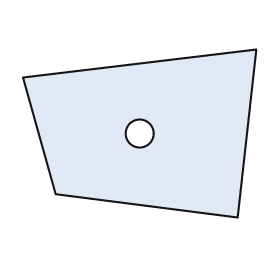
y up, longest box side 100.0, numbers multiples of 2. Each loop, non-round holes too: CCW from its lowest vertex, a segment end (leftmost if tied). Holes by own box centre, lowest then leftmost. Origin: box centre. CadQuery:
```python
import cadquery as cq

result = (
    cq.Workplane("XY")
    .moveTo(42.0, -36.0)
    .lineTo(50.0, 36.0)
    .lineTo(-50.0, 24.0)
    .lineTo(-36.0, -26.0)
    .close()
    .moveTo(0.0, 0.0)
    .circle(6.0)
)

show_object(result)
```